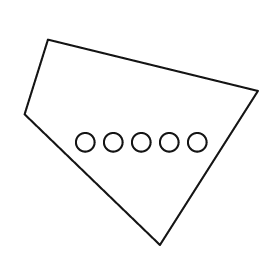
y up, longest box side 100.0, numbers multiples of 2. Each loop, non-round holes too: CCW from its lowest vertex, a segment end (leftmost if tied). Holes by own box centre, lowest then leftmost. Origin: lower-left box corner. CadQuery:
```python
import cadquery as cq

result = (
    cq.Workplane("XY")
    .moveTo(58.0, 0.0)
    .lineTo(100.0, 66.0)
    .lineTo(10.0, 88.0)
    .lineTo(0.0, 56.0)
    .close()
    .moveTo(26.0, 44.0)
    .circle(4.0)
    .moveTo(38.0, 44.0)
    .circle(4.0)
    .moveTo(50.0, 44.0)
    .circle(4.0)
    .moveTo(62.0, 44.0)
    .circle(4.0)
    .moveTo(74.0, 44.0)
    .circle(4.0)
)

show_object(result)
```